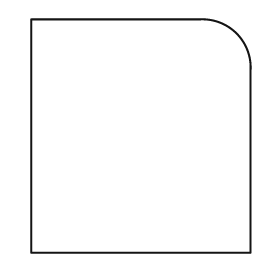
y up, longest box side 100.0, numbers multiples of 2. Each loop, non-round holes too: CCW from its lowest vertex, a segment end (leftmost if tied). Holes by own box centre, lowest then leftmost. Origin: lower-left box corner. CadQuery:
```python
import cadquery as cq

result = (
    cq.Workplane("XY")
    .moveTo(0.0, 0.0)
    .lineTo(94.0, 0.0)
    .lineTo(94.0, 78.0)
    .threePointArc((88.0, 94.0), (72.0, 100.0))
    .lineTo(0.0, 100.0)
    .close()
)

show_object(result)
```